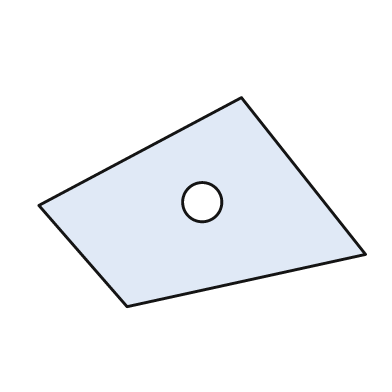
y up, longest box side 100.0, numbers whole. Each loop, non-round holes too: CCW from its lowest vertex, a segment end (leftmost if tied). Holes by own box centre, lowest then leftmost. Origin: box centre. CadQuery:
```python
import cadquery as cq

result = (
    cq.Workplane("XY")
    .moveTo(-23.0, -32.0)
    .lineTo(50.0, -16.0)
    .lineTo(12.0, 32.0)
    .lineTo(-50.0, -1.0)
    .close()
    .moveTo(0.0, 0.0)
    .circle(6.0)
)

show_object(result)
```